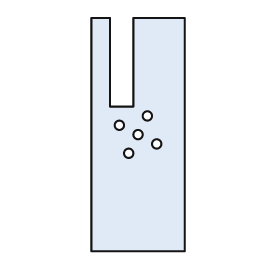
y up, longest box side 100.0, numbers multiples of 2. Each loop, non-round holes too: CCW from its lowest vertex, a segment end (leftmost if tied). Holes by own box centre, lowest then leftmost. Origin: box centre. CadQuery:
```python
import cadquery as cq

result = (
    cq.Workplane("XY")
    .moveTo(-20.0, -50.0)
    .lineTo(20.0, -50.0)
    .lineTo(20.0, 50.0)
    .lineTo(-2.0, 50.0)
    .lineTo(-2.0, 12.0)
    .lineTo(-12.0, 12.0)
    .lineTo(-12.0, 50.0)
    .lineTo(-20.0, 50.0)
    .close()
    .moveTo(-4.0, -8.0)
    .circle(2.0)
    .moveTo(8.0, -4.0)
    .circle(2.0)
    .moveTo(0.0, 0.0)
    .circle(2.0)
    .moveTo(-8.0, 4.0)
    .circle(2.0)
    .moveTo(4.0, 8.0)
    .circle(2.0)
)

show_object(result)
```